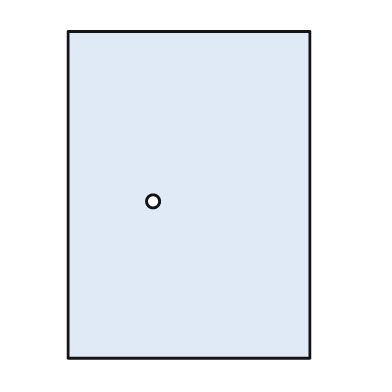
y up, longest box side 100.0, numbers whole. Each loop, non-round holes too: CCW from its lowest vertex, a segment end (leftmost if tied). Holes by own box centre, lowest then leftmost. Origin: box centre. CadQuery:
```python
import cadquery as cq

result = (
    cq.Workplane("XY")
    .moveTo(-37.0, -50.0)
    .lineTo(37.0, -50.0)
    .lineTo(37.0, 50.0)
    .lineTo(-37.0, 50.0)
    .close()
    .moveTo(-11.0, -2.0)
    .circle(2.0)
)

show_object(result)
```